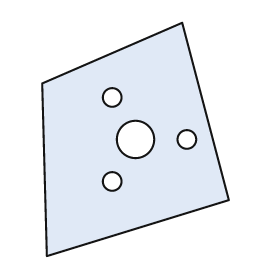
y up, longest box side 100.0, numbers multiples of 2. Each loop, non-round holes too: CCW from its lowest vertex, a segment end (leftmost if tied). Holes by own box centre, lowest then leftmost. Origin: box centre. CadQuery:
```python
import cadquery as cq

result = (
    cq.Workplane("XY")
    .moveTo(-38.0, -50.0)
    .lineTo(40.0, -26.0)
    .lineTo(20.0, 50.0)
    .lineTo(-40.0, 24.0)
    .close()
    .moveTo(-10.0, -18.0)
    .circle(4.0)
    .moveTo(0.0, 0.0)
    .circle(8.0)
    .moveTo(22.0, 0.0)
    .circle(4.0)
    .moveTo(-10.0, 18.0)
    .circle(4.0)
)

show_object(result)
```